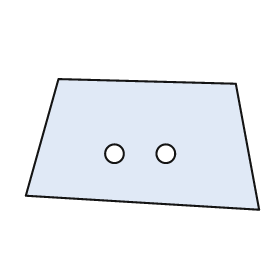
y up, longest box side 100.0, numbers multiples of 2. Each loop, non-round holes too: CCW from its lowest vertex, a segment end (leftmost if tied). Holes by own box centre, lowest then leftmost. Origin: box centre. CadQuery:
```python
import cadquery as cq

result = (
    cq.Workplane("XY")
    .moveTo(50.0, -28.0)
    .lineTo(40.0, 26.0)
    .lineTo(-36.0, 28.0)
    .lineTo(-50.0, -22.0)
    .close()
    .moveTo(-12.0, -4.0)
    .circle(4.0)
    .moveTo(10.0, -4.0)
    .circle(4.0)
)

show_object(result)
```